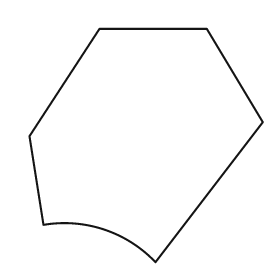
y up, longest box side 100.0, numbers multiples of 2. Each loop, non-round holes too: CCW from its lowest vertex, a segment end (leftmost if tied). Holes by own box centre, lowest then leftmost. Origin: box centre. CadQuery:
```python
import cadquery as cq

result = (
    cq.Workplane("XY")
    .moveTo(4.0, -50.0)
    .lineTo(50.0, 10.0)
    .lineTo(26.0, 50.0)
    .lineTo(-20.0, 50.0)
    .lineTo(-50.0, 4.0)
    .lineTo(-44.0, -34.0)
    .threePointArc((-18.0, -36.0), (4.0, -50.0))
    .close()
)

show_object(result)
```